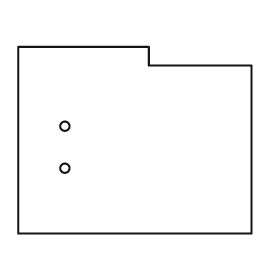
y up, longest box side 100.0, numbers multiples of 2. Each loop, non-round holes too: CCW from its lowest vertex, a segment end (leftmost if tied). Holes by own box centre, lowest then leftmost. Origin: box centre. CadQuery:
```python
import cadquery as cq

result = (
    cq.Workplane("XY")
    .moveTo(-50.0, -40.0)
    .lineTo(50.0, -40.0)
    .lineTo(50.0, 32.0)
    .lineTo(6.0, 32.0)
    .lineTo(6.0, 40.0)
    .lineTo(-50.0, 40.0)
    .close()
    .moveTo(-30.0, -12.0)
    .circle(2.0)
    .moveTo(-30.0, 6.0)
    .circle(2.0)
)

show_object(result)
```